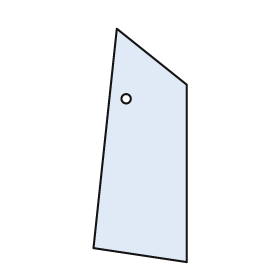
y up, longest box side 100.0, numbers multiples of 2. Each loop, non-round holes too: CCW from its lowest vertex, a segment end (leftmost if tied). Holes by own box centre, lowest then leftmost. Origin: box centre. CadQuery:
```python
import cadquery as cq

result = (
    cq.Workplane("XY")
    .moveTo(20.0, -50.0)
    .lineTo(20.0, 26.0)
    .lineTo(-10.0, 50.0)
    .lineTo(-20.0, -44.0)
    .close()
    .moveTo(-6.0, 20.0)
    .circle(2.0)
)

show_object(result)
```